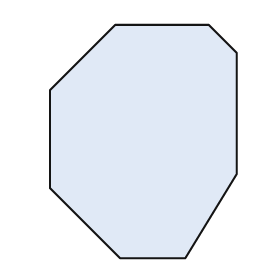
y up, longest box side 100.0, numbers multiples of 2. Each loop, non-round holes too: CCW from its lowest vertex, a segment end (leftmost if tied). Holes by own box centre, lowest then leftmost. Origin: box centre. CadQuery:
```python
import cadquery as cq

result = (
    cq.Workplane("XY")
    .moveTo(-10.0, -50.0)
    .lineTo(18.0, -50.0)
    .lineTo(40.0, -14.0)
    .lineTo(40.0, 38.0)
    .lineTo(28.0, 50.0)
    .lineTo(-12.0, 50.0)
    .lineTo(-40.0, 22.0)
    .lineTo(-40.0, -20.0)
    .close()
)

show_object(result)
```